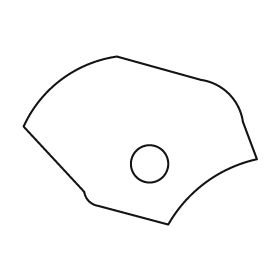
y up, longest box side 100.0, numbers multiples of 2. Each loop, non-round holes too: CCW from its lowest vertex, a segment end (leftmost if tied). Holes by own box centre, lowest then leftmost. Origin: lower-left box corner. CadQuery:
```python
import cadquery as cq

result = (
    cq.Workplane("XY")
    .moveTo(62.0, 0.0)
    .threePointArc((78.0, 18.0), (100.0, 28.0))
    .lineTo(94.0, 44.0)
    .threePointArc((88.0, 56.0), (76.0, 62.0))
    .lineTo(40.0, 72.0)
    .threePointArc((16.0, 62.0), (0.0, 42.0))
    .lineTo(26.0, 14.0)
    .threePointArc((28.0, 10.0), (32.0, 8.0))
    .close()
    .moveTo(54.0, 26.0)
    .circle(8.0)
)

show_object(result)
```